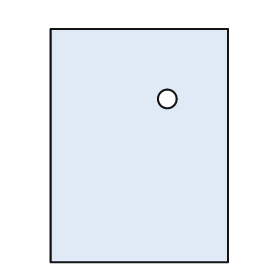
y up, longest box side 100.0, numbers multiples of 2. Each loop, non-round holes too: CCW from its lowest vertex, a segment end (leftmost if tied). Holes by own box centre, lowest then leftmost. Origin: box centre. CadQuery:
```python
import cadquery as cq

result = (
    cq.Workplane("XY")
    .moveTo(-38.0, -50.0)
    .lineTo(38.0, -50.0)
    .lineTo(38.0, 50.0)
    .lineTo(-38.0, 50.0)
    .close()
    .moveTo(12.0, 20.0)
    .circle(4.0)
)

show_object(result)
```